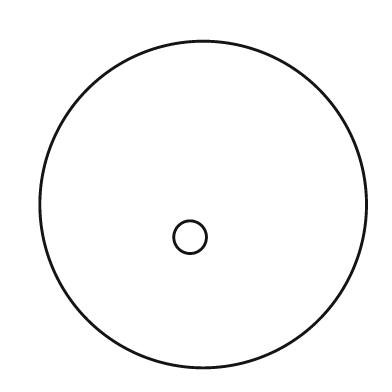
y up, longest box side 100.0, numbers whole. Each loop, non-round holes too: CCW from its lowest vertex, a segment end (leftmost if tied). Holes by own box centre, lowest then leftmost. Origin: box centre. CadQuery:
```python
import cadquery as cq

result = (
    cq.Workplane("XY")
    .moveTo(0.0, 0.0)
    .circle(50.0)
    .moveTo(-4.0, -10.0)
    .circle(5.0)
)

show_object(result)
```